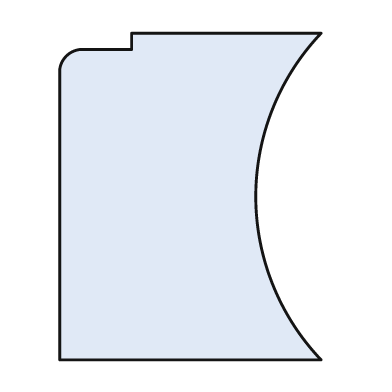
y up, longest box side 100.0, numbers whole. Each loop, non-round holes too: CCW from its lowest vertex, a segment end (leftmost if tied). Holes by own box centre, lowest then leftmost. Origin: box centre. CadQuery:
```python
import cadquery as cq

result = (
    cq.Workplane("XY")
    .moveTo(-40.0, -50.0)
    .lineTo(40.0, -50.0)
    .threePointArc((20.0, 0.0), (40.0, 50.0))
    .lineTo(-18.0, 50.0)
    .lineTo(-18.0, 45.0)
    .lineTo(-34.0, 45.0)
    .threePointArc((-38.0, 43.0), (-40.0, 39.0))
    .close()
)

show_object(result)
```